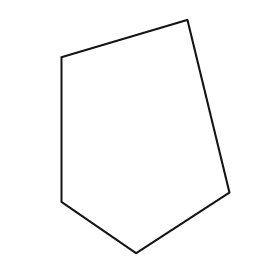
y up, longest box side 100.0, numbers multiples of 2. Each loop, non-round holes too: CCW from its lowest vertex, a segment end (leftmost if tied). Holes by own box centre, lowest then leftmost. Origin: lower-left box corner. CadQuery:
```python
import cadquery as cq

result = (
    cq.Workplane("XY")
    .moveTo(32.0, 0.0)
    .lineTo(72.0, 26.0)
    .lineTo(54.0, 100.0)
    .lineTo(0.0, 84.0)
    .lineTo(0.0, 22.0)
    .close()
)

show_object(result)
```